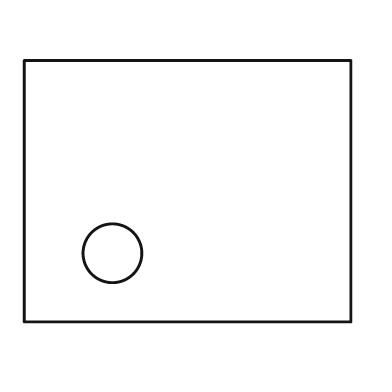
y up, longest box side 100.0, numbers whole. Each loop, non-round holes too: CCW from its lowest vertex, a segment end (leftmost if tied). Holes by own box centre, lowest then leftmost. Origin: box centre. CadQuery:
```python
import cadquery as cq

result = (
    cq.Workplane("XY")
    .moveTo(-50.0, -40.0)
    .lineTo(50.0, -40.0)
    .lineTo(50.0, 40.0)
    .lineTo(-50.0, 40.0)
    .close()
    .moveTo(-23.0, -19.0)
    .circle(9.0)
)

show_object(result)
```